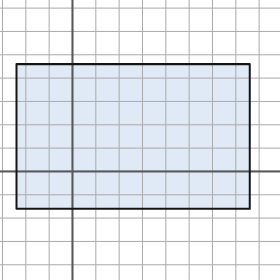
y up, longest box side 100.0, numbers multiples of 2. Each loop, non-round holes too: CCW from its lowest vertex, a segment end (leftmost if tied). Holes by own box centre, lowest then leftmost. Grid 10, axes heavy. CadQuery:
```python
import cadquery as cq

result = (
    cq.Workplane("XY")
    .moveTo(-24.0, -16.0)
    .lineTo(76.0, -16.0)
    .lineTo(76.0, 46.0)
    .lineTo(-24.0, 46.0)
    .close()
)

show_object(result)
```